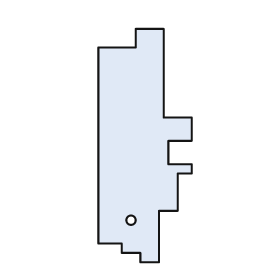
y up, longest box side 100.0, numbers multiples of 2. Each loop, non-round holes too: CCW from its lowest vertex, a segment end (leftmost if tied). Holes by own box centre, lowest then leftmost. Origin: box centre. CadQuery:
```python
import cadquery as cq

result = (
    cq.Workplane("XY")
    .moveTo(-2.0, -50.0)
    .lineTo(6.0, -50.0)
    .lineTo(6.0, -28.0)
    .lineTo(14.0, -28.0)
    .lineTo(14.0, -12.0)
    .lineTo(20.0, -12.0)
    .lineTo(20.0, -8.0)
    .lineTo(10.0, -8.0)
    .lineTo(10.0, 2.0)
    .lineTo(20.0, 2.0)
    .lineTo(20.0, 12.0)
    .lineTo(8.0, 12.0)
    .lineTo(8.0, 50.0)
    .lineTo(-4.0, 50.0)
    .lineTo(-4.0, 42.0)
    .lineTo(-20.0, 42.0)
    .lineTo(-20.0, -42.0)
    .lineTo(-10.0, -42.0)
    .lineTo(-10.0, -46.0)
    .lineTo(-2.0, -46.0)
    .close()
    .moveTo(-6.0, -32.0)
    .circle(2.0)
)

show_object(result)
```